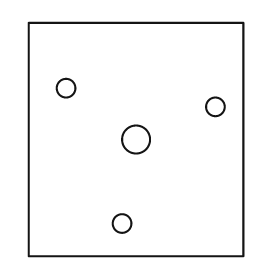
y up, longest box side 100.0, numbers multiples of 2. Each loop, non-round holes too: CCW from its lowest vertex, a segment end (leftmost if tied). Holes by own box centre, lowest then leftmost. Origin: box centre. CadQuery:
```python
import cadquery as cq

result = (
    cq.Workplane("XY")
    .moveTo(-46.0, -50.0)
    .lineTo(46.0, -50.0)
    .lineTo(46.0, 50.0)
    .lineTo(-46.0, 50.0)
    .close()
    .moveTo(-6.0, -36.0)
    .circle(4.0)
    .moveTo(0.0, 0.0)
    .circle(6.0)
    .moveTo(34.0, 14.0)
    .circle(4.0)
    .moveTo(-30.0, 22.0)
    .circle(4.0)
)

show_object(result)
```